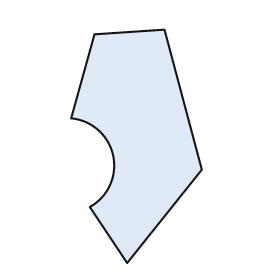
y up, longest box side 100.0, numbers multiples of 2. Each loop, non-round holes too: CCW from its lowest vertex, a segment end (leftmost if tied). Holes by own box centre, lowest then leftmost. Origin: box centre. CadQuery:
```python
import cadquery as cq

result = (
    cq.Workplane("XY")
    .moveTo(-4.0, -50.0)
    .lineTo(28.0, -10.0)
    .lineTo(12.0, 50.0)
    .lineTo(-18.0, 48.0)
    .lineTo(-28.0, 12.0)
    .threePointArc((-10.0, -4.0), (-20.0, -26.0))
    .close()
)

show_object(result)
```